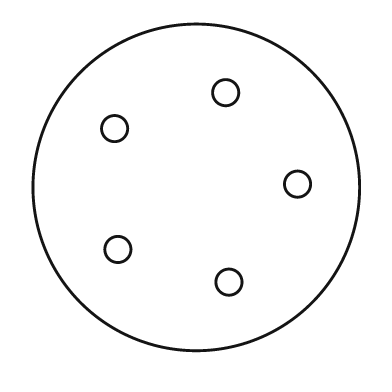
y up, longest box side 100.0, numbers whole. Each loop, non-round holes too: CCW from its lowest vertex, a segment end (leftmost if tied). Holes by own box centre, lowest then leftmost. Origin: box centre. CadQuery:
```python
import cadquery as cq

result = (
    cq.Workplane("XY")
    .moveTo(0.0, 0.0)
    .circle(50.0)
    .moveTo(10.0, -29.0)
    .circle(4.0)
    .moveTo(-24.0, -19.0)
    .circle(4.0)
    .moveTo(31.0, 1.0)
    .circle(4.0)
    .moveTo(-25.0, 18.0)
    .circle(4.0)
    .moveTo(9.0, 29.0)
    .circle(4.0)
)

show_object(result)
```